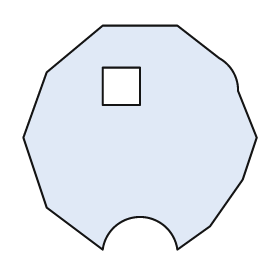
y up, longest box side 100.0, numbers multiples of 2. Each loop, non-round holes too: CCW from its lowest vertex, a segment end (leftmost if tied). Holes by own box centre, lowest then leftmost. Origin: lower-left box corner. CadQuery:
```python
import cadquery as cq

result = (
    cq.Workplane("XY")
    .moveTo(34.0, 0.0)
    .threePointArc((50.0, 14.0), (66.0, 0.0))
    .lineTo(80.0, 10.0)
    .lineTo(94.0, 30.0)
    .lineTo(100.0, 48.0)
    .lineTo(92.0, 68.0)
    .threePointArc((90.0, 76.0), (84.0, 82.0))
    .lineTo(66.0, 96.0)
    .lineTo(34.0, 96.0)
    .lineTo(10.0, 76.0)
    .lineTo(0.0, 48.0)
    .lineTo(10.0, 18.0)
    .close()
    .moveTo(34.0, 62.0)
    .lineTo(50.0, 62.0)
    .lineTo(50.0, 78.0)
    .lineTo(34.0, 78.0)
    .close()
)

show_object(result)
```